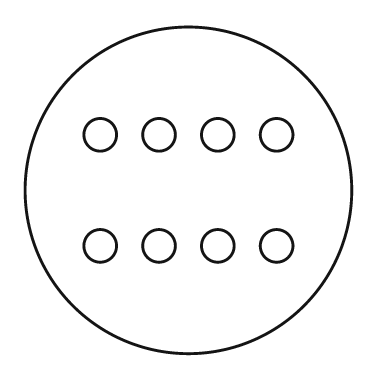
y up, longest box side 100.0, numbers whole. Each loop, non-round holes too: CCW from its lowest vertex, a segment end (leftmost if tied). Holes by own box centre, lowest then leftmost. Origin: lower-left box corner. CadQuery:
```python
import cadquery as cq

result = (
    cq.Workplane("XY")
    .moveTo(50.0, 50.0)
    .circle(50.0)
    .moveTo(23.0, 33.0)
    .circle(5.0)
    .moveTo(41.0, 33.0)
    .circle(5.0)
    .moveTo(59.0, 33.0)
    .circle(5.0)
    .moveTo(77.0, 33.0)
    .circle(5.0)
    .moveTo(23.0, 67.0)
    .circle(5.0)
    .moveTo(41.0, 67.0)
    .circle(5.0)
    .moveTo(59.0, 67.0)
    .circle(5.0)
    .moveTo(77.0, 67.0)
    .circle(5.0)
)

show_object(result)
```